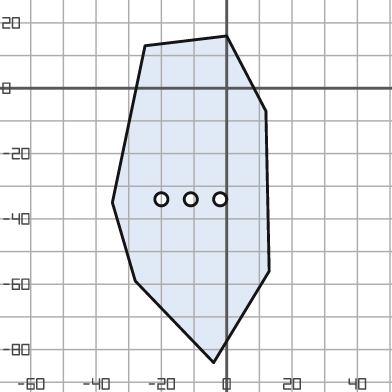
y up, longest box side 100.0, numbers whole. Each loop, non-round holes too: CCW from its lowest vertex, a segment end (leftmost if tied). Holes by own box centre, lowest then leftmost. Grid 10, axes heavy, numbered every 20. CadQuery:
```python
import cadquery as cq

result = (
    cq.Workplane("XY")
    .moveTo(-4.0, -84.0)
    .lineTo(13.0, -56.0)
    .lineTo(12.0, -7.0)
    .lineTo(0.0, 16.0)
    .lineTo(-25.0, 13.0)
    .lineTo(-35.0, -35.0)
    .lineTo(-28.0, -59.0)
    .close()
    .moveTo(-20.0, -34.0)
    .circle(2.0)
    .moveTo(-11.0, -34.0)
    .circle(2.0)
    .moveTo(-2.0, -34.0)
    .circle(2.0)
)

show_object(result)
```